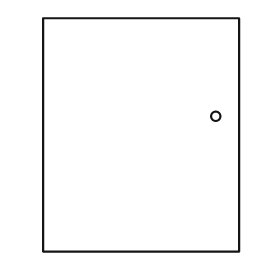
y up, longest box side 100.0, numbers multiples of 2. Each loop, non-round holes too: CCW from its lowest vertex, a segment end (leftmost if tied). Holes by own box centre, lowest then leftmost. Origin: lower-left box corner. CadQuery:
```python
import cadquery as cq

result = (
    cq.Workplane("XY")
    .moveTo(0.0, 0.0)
    .lineTo(84.0, 0.0)
    .lineTo(84.0, 100.0)
    .lineTo(0.0, 100.0)
    .close()
    .moveTo(74.0, 58.0)
    .circle(2.0)
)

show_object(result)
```